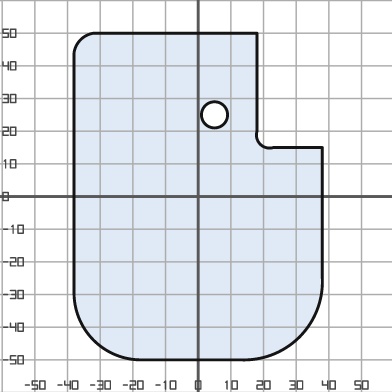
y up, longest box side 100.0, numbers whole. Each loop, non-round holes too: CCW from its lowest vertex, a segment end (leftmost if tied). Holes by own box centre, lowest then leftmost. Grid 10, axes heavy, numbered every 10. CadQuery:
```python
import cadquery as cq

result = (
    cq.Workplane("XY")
    .moveTo(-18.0, -50.0)
    .lineTo(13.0, -50.0)
    .threePointArc((31.0, -43.0), (38.0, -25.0))
    .lineTo(38.0, 15.0)
    .lineTo(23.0, 15.0)
    .threePointArc((19.0, 16.0), (18.0, 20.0))
    .lineTo(18.0, 50.0)
    .lineTo(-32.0, 50.0)
    .threePointArc((-36.0, 48.0), (-38.0, 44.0))
    .lineTo(-38.0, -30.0)
    .threePointArc((-32.0, -44.0), (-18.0, -50.0))
    .close()
    .moveTo(5.0, 25.0)
    .circle(4.0)
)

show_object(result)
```